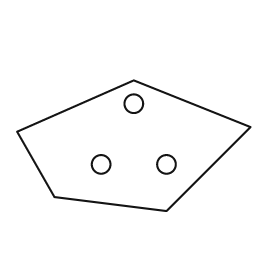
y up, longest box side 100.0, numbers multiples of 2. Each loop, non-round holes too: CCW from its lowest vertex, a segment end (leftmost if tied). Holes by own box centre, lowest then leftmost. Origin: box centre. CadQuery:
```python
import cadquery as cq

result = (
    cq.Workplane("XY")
    .moveTo(14.0, -28.0)
    .lineTo(50.0, 8.0)
    .lineTo(0.0, 28.0)
    .lineTo(-50.0, 6.0)
    .lineTo(-34.0, -22.0)
    .close()
    .moveTo(-14.0, -8.0)
    .circle(4.0)
    .moveTo(14.0, -8.0)
    .circle(4.0)
    .moveTo(0.0, 18.0)
    .circle(4.0)
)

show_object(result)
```